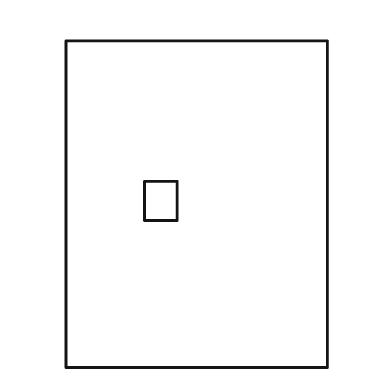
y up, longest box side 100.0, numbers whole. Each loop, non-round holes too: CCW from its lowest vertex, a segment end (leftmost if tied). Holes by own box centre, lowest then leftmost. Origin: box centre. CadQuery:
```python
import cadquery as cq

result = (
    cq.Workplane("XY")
    .moveTo(-40.0, -50.0)
    .lineTo(40.0, -50.0)
    .lineTo(40.0, 50.0)
    .lineTo(-40.0, 50.0)
    .close()
    .moveTo(-16.0, -5.0)
    .lineTo(-6.0, -5.0)
    .lineTo(-6.0, 7.0)
    .lineTo(-16.0, 7.0)
    .close()
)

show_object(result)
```